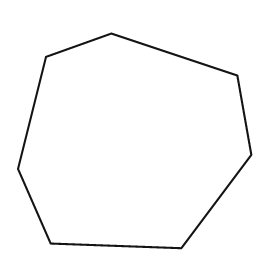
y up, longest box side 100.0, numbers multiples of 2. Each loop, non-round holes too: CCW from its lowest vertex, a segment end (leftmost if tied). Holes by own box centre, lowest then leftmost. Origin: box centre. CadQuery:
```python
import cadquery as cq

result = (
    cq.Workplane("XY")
    .moveTo(20.0, -46.0)
    .lineTo(50.0, -6.0)
    .lineTo(44.0, 28.0)
    .lineTo(-10.0, 46.0)
    .lineTo(-38.0, 36.0)
    .lineTo(-50.0, -12.0)
    .lineTo(-36.0, -44.0)
    .close()
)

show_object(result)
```